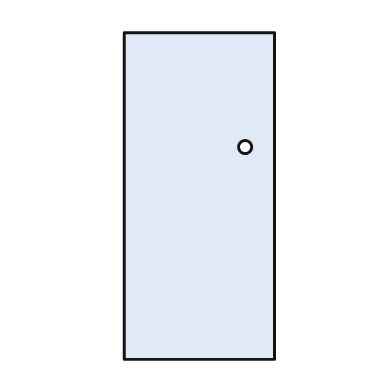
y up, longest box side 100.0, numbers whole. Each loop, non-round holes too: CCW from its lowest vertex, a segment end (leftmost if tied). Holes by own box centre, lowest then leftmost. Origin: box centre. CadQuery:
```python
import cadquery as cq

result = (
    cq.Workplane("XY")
    .moveTo(-23.0, -50.0)
    .lineTo(23.0, -50.0)
    .lineTo(23.0, 50.0)
    .lineTo(-23.0, 50.0)
    .close()
    .moveTo(14.0, 15.0)
    .circle(2.0)
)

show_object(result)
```